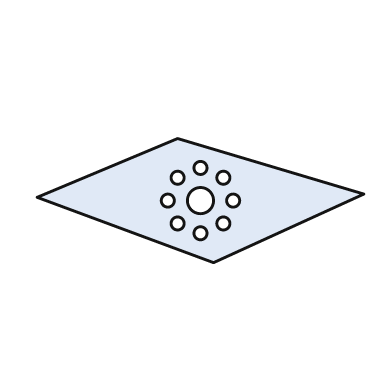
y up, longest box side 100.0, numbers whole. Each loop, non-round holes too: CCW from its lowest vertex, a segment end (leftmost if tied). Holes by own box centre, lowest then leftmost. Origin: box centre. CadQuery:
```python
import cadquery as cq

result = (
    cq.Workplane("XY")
    .moveTo(4.0, -19.0)
    .lineTo(50.0, 2.0)
    .lineTo(-7.0, 19.0)
    .lineTo(-50.0, 1.0)
    .close()
    .moveTo(0.0, -10.0)
    .circle(2.0)
    .moveTo(-7.0, -7.0)
    .circle(2.0)
    .moveTo(7.0, -7.0)
    .circle(2.0)
    .moveTo(-10.0, 0.0)
    .circle(2.0)
    .moveTo(0.0, 0.0)
    .circle(4.0)
    .moveTo(10.0, 0.0)
    .circle(2.0)
    .moveTo(-7.0, 7.0)
    .circle(2.0)
    .moveTo(7.0, 7.0)
    .circle(2.0)
    .moveTo(0.0, 10.0)
    .circle(2.0)
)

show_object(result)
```